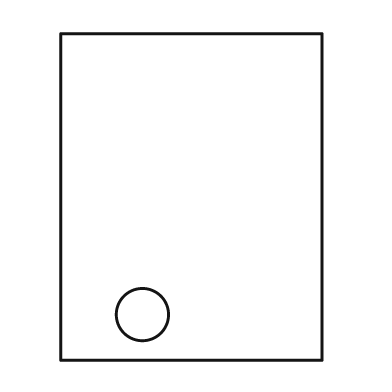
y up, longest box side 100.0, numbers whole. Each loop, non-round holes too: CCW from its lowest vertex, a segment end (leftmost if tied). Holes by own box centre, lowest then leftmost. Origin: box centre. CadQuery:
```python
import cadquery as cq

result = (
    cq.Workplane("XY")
    .moveTo(-40.0, -50.0)
    .lineTo(40.0, -50.0)
    .lineTo(40.0, 50.0)
    .lineTo(-40.0, 50.0)
    .close()
    .moveTo(-15.0, -36.0)
    .circle(8.0)
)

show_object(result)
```